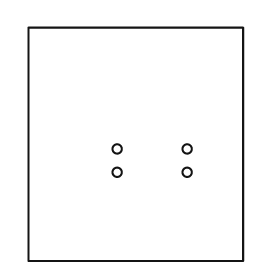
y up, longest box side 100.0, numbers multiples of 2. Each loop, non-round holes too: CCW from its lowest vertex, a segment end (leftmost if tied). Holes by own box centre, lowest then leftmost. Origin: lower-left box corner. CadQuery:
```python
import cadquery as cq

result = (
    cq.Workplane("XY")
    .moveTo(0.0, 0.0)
    .lineTo(92.0, 0.0)
    .lineTo(92.0, 100.0)
    .lineTo(0.0, 100.0)
    .close()
    .moveTo(38.0, 38.0)
    .circle(2.0)
    .moveTo(68.0, 38.0)
    .circle(2.0)
    .moveTo(38.0, 48.0)
    .circle(2.0)
    .moveTo(68.0, 48.0)
    .circle(2.0)
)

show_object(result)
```